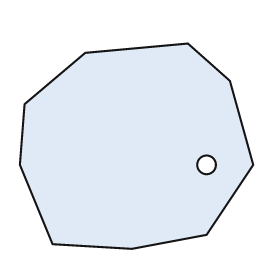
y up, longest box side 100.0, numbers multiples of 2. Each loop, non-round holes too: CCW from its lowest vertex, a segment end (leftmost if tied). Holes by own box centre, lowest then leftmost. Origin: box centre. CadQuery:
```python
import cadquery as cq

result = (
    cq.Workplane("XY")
    .moveTo(-2.0, -44.0)
    .lineTo(30.0, -38.0)
    .lineTo(50.0, -8.0)
    .lineTo(40.0, 28.0)
    .lineTo(22.0, 44.0)
    .lineTo(-22.0, 40.0)
    .lineTo(-48.0, 18.0)
    .lineTo(-50.0, -8.0)
    .lineTo(-36.0, -42.0)
    .close()
    .moveTo(30.0, -8.0)
    .circle(4.0)
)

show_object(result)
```